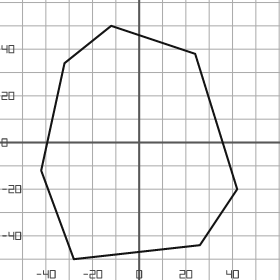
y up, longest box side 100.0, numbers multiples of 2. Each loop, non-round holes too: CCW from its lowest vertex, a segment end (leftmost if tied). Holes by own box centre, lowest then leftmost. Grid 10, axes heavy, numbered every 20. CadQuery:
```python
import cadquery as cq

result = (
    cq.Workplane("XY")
    .moveTo(-28.0, -50.0)
    .lineTo(26.0, -44.0)
    .lineTo(42.0, -20.0)
    .lineTo(24.0, 38.0)
    .lineTo(-12.0, 50.0)
    .lineTo(-32.0, 34.0)
    .lineTo(-42.0, -12.0)
    .close()
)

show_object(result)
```